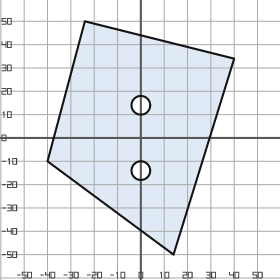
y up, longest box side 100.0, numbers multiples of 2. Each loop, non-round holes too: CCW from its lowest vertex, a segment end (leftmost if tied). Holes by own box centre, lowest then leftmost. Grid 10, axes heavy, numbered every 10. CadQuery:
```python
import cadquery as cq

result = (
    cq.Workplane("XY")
    .moveTo(14.0, -50.0)
    .lineTo(40.0, 34.0)
    .lineTo(-24.0, 50.0)
    .lineTo(-40.0, -10.0)
    .close()
    .moveTo(0.0, -14.0)
    .circle(4.0)
    .moveTo(0.0, 14.0)
    .circle(4.0)
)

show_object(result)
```